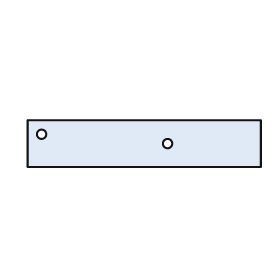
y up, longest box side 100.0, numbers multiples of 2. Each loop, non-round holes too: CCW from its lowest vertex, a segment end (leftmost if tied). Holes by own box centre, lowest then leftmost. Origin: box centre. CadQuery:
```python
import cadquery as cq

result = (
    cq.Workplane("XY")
    .moveTo(-50.0, -10.0)
    .lineTo(50.0, -10.0)
    .lineTo(50.0, 10.0)
    .lineTo(-50.0, 10.0)
    .close()
    .moveTo(10.0, 0.0)
    .circle(2.0)
    .moveTo(-44.0, 4.0)
    .circle(2.0)
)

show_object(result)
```